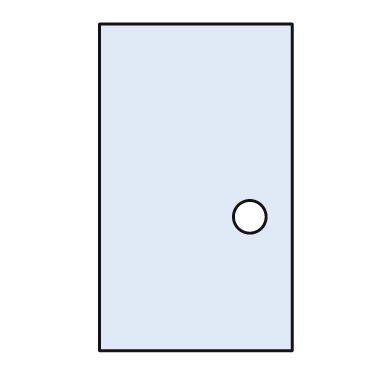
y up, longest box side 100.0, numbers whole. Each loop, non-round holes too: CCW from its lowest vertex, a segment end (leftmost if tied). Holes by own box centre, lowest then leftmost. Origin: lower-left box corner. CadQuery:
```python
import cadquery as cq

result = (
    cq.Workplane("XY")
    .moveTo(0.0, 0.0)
    .lineTo(59.0, 0.0)
    .lineTo(59.0, 100.0)
    .lineTo(0.0, 100.0)
    .close()
    .moveTo(46.0, 41.0)
    .circle(5.0)
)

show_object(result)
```